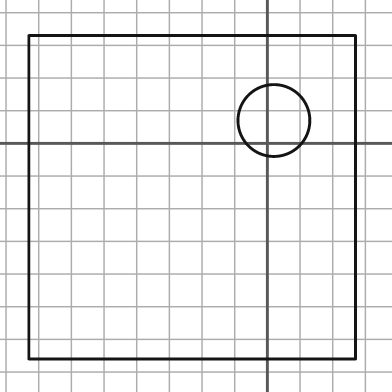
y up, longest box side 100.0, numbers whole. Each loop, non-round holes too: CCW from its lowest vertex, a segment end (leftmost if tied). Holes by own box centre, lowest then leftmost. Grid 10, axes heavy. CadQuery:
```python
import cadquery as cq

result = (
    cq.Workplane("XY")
    .moveTo(-73.0, -66.0)
    .lineTo(27.0, -66.0)
    .lineTo(27.0, 33.0)
    .lineTo(-73.0, 33.0)
    .close()
    .moveTo(2.0, 7.0)
    .circle(11.0)
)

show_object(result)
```